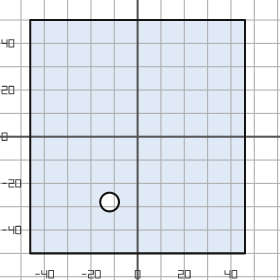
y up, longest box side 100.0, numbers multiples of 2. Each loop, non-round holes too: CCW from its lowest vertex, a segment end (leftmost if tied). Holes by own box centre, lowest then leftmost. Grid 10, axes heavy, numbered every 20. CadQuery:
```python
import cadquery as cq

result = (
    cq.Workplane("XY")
    .moveTo(-46.0, -50.0)
    .lineTo(46.0, -50.0)
    .lineTo(46.0, 50.0)
    .lineTo(-46.0, 50.0)
    .close()
    .moveTo(-12.0, -28.0)
    .circle(4.0)
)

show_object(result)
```